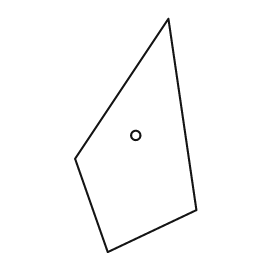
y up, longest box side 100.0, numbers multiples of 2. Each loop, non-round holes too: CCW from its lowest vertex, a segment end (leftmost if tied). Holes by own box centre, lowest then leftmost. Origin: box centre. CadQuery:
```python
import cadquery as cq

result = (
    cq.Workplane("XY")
    .moveTo(-12.0, -50.0)
    .lineTo(26.0, -32.0)
    .lineTo(14.0, 50.0)
    .lineTo(-26.0, -10.0)
    .close()
    .moveTo(0.0, 0.0)
    .circle(2.0)
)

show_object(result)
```